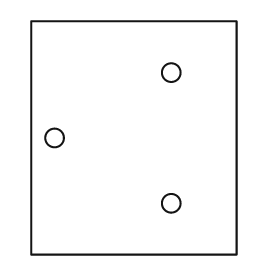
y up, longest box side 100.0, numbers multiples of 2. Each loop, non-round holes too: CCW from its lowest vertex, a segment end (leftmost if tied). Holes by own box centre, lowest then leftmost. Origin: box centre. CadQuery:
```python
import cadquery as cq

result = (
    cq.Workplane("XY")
    .moveTo(-44.0, -50.0)
    .lineTo(44.0, -50.0)
    .lineTo(44.0, 50.0)
    .lineTo(-44.0, 50.0)
    .close()
    .moveTo(16.0, -28.0)
    .circle(4.0)
    .moveTo(-34.0, 0.0)
    .circle(4.0)
    .moveTo(16.0, 28.0)
    .circle(4.0)
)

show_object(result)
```